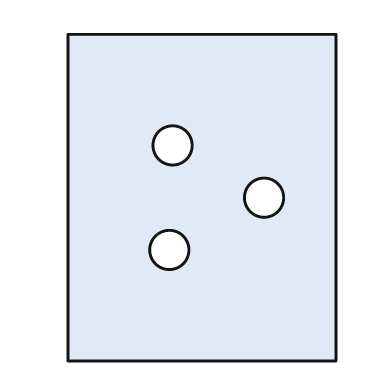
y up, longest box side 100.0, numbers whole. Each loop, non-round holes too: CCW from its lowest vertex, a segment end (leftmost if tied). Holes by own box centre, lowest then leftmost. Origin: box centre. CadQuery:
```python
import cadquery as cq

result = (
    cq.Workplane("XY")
    .moveTo(-41.0, -50.0)
    .lineTo(41.0, -50.0)
    .lineTo(41.0, 50.0)
    .lineTo(-41.0, 50.0)
    .close()
    .moveTo(-10.0, -16.0)
    .circle(6.0)
    .moveTo(19.0, 0.0)
    .circle(6.0)
    .moveTo(-9.0, 16.0)
    .circle(6.0)
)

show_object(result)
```